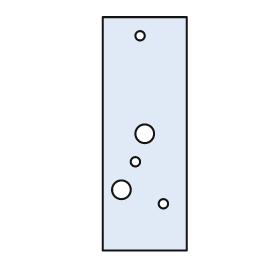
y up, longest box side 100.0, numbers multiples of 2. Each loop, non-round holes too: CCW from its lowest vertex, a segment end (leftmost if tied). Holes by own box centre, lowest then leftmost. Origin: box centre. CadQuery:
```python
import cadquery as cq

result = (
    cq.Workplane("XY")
    .moveTo(-18.0, -50.0)
    .lineTo(18.0, -50.0)
    .lineTo(18.0, 50.0)
    .lineTo(-18.0, 50.0)
    .close()
    .moveTo(8.0, -30.0)
    .circle(2.0)
    .moveTo(-10.0, -24.0)
    .circle(4.0)
    .moveTo(-4.0, -12.0)
    .circle(2.0)
    .moveTo(0.0, 0.0)
    .circle(4.0)
    .moveTo(-2.0, 42.0)
    .circle(2.0)
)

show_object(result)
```